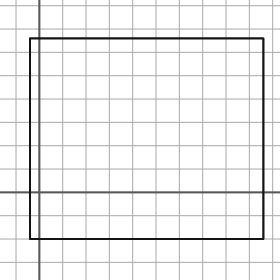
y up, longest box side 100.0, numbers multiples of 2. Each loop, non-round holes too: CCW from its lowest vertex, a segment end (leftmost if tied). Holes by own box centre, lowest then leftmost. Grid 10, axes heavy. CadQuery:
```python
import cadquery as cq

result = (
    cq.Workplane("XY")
    .moveTo(-4.0, -20.0)
    .lineTo(96.0, -20.0)
    .lineTo(96.0, 66.0)
    .lineTo(-4.0, 66.0)
    .close()
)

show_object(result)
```